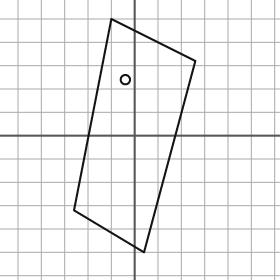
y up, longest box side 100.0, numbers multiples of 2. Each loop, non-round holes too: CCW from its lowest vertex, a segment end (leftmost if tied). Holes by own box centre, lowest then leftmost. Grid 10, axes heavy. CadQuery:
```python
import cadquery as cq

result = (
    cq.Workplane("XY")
    .moveTo(4.0, -50.0)
    .lineTo(26.0, 32.0)
    .lineTo(-10.0, 50.0)
    .lineTo(-26.0, -32.0)
    .close()
    .moveTo(-4.0, 24.0)
    .circle(2.0)
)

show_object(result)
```